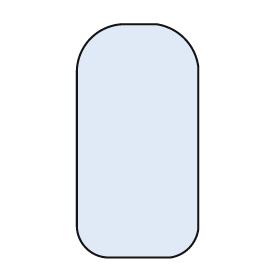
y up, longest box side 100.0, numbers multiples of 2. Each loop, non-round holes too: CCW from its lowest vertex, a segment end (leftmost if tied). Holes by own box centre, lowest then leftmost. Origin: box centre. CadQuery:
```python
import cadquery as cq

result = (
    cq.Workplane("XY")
    .moveTo(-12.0, -50.0)
    .lineTo(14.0, -50.0)
    .threePointArc((22.0, -46.0), (26.0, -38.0))
    .lineTo(26.0, 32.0)
    .threePointArc((20.0, 44.0), (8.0, 50.0))
    .lineTo(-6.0, 50.0)
    .threePointArc((-20.0, 44.0), (-26.0, 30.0))
    .lineTo(-26.0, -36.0)
    .threePointArc((-22.0, -46.0), (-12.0, -50.0))
    .close()
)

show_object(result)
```